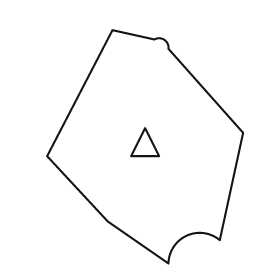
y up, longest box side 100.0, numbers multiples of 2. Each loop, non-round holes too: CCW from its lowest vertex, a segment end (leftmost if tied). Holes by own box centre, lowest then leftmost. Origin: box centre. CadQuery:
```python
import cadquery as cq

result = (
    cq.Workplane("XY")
    .moveTo(10.0, -50.0)
    .threePointArc((18.0, -38.0), (32.0, -40.0))
    .lineTo(42.0, 6.0)
    .lineTo(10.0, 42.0)
    .threePointArc((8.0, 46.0), (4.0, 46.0))
    .lineTo(-14.0, 50.0)
    .lineTo(-42.0, -4.0)
    .lineTo(-16.0, -32.0)
    .close()
    .moveTo(-6.0, -4.0)
    .lineTo(6.0, -4.0)
    .lineTo(0.0, 8.0)
    .close()
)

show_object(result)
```